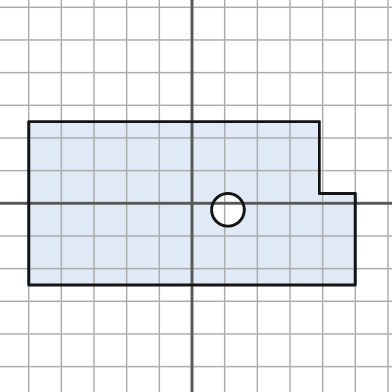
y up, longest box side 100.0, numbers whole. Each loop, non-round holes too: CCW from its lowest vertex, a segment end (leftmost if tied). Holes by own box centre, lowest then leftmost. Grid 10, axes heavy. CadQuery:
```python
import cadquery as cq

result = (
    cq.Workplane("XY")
    .moveTo(-50.0, -25.0)
    .lineTo(50.0, -25.0)
    .lineTo(50.0, 3.0)
    .lineTo(39.0, 3.0)
    .lineTo(39.0, 25.0)
    .lineTo(-50.0, 25.0)
    .close()
    .moveTo(11.0, -2.0)
    .circle(5.0)
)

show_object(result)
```